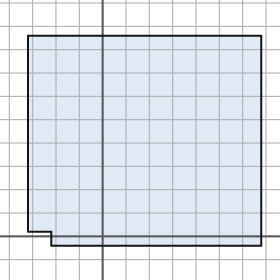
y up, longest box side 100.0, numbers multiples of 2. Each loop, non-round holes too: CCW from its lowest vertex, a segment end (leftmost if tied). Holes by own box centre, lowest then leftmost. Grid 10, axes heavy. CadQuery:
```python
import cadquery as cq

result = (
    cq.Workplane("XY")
    .moveTo(-22.0, -4.0)
    .lineTo(68.0, -4.0)
    .lineTo(68.0, 86.0)
    .lineTo(-32.0, 86.0)
    .lineTo(-32.0, 2.0)
    .lineTo(-22.0, 2.0)
    .close()
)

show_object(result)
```